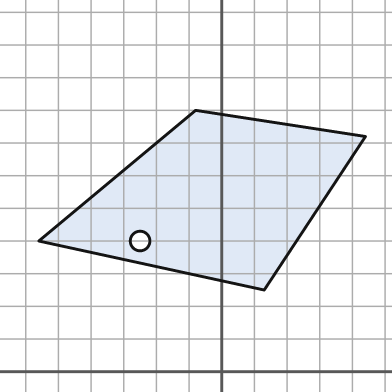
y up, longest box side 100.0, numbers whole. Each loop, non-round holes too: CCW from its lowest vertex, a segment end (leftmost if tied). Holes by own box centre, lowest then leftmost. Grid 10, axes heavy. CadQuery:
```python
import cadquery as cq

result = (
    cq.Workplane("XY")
    .moveTo(13.0, 25.0)
    .lineTo(44.0, 72.0)
    .lineTo(-8.0, 80.0)
    .lineTo(-56.0, 40.0)
    .close()
    .moveTo(-25.0, 40.0)
    .circle(3.0)
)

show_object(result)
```